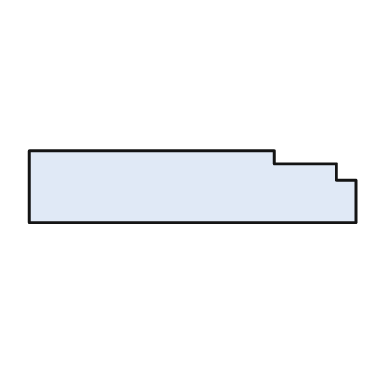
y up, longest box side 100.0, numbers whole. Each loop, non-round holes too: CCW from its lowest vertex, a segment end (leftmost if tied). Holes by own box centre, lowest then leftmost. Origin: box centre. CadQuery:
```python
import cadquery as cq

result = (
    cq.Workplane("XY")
    .moveTo(-50.0, -11.0)
    .lineTo(50.0, -11.0)
    .lineTo(50.0, 2.0)
    .lineTo(44.0, 2.0)
    .lineTo(44.0, 7.0)
    .lineTo(25.0, 7.0)
    .lineTo(25.0, 11.0)
    .lineTo(-50.0, 11.0)
    .close()
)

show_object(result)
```